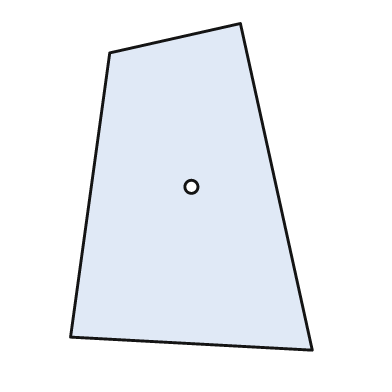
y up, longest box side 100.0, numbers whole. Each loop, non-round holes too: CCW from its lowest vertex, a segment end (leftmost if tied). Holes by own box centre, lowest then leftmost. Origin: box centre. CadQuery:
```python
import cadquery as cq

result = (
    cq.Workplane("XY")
    .moveTo(37.0, -50.0)
    .lineTo(15.0, 50.0)
    .lineTo(-25.0, 41.0)
    .lineTo(-37.0, -46.0)
    .close()
    .moveTo(0.0, 0.0)
    .circle(2.0)
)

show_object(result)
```